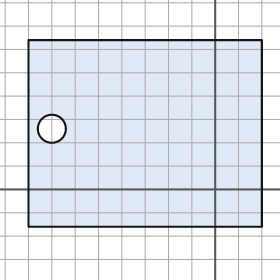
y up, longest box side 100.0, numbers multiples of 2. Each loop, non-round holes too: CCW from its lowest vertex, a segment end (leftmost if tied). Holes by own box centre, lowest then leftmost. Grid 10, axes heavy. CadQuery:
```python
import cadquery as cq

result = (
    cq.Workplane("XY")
    .moveTo(-80.0, -16.0)
    .lineTo(20.0, -16.0)
    .lineTo(20.0, 64.0)
    .lineTo(-80.0, 64.0)
    .close()
    .moveTo(-70.0, 26.0)
    .circle(6.0)
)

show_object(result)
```